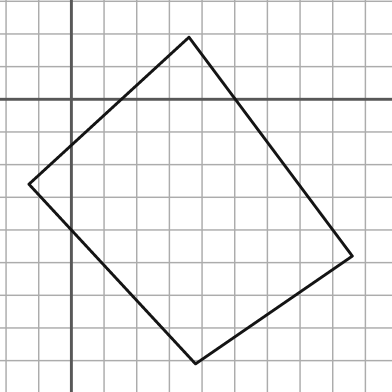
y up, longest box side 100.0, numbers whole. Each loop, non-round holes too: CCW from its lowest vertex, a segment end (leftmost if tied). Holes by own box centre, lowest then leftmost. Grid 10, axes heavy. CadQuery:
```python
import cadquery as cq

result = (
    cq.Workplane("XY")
    .moveTo(38.0, -81.0)
    .lineTo(86.0, -48.0)
    .lineTo(36.0, 19.0)
    .lineTo(-13.0, -26.0)
    .close()
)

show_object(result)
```